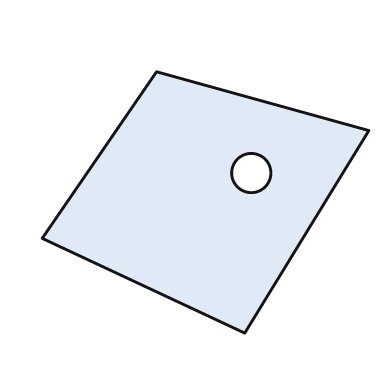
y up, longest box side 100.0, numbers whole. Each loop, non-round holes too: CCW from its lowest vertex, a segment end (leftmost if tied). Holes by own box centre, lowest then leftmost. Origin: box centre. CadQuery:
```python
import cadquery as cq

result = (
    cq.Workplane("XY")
    .moveTo(12.0, -40.0)
    .lineTo(50.0, 22.0)
    .lineTo(-15.0, 40.0)
    .lineTo(-50.0, -11.0)
    .close()
    .moveTo(14.0, 9.0)
    .circle(6.0)
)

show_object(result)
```